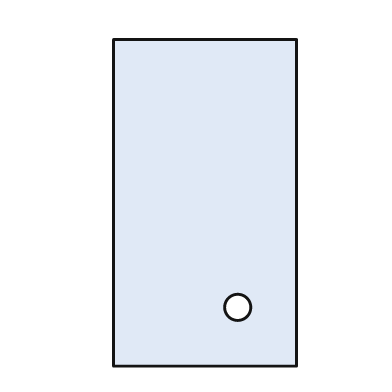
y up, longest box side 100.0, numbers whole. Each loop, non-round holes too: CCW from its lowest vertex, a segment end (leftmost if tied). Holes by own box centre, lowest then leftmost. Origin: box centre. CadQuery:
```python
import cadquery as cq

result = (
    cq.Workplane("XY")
    .moveTo(-28.0, -50.0)
    .lineTo(28.0, -50.0)
    .lineTo(28.0, 50.0)
    .lineTo(-28.0, 50.0)
    .close()
    .moveTo(10.0, -32.0)
    .circle(4.0)
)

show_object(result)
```